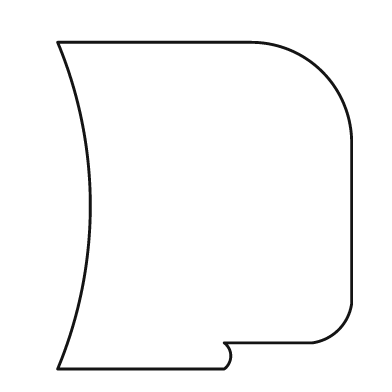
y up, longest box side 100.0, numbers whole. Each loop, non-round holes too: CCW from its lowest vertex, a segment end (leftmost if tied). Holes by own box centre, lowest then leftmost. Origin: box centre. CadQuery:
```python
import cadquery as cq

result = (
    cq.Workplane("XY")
    .moveTo(-45.0, -50.0)
    .lineTo(6.0, -50.0)
    .threePointArc((8.0, -46.0), (6.0, -42.0))
    .lineTo(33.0, -42.0)
    .threePointArc((41.0, -38.0), (45.0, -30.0))
    .lineTo(45.0, 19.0)
    .threePointArc((36.0, 41.0), (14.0, 50.0))
    .lineTo(-45.0, 50.0)
    .threePointArc((-35.0, 0.0), (-45.0, -50.0))
    .close()
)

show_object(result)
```